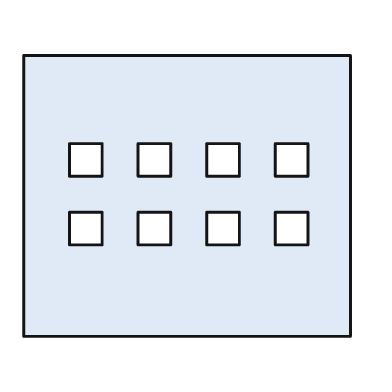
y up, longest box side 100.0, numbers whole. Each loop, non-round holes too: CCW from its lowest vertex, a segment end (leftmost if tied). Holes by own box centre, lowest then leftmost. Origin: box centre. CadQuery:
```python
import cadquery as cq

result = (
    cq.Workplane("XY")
    .moveTo(-50.0, -43.0)
    .lineTo(50.0, -43.0)
    .lineTo(50.0, 43.0)
    .lineTo(-50.0, 43.0)
    .close()
    .moveTo(-36.0, -15.0)
    .lineTo(-26.0, -15.0)
    .lineTo(-26.0, -5.0)
    .lineTo(-36.0, -5.0)
    .close()
    .moveTo(-15.0, -15.0)
    .lineTo(-5.0, -15.0)
    .lineTo(-5.0, -5.0)
    .lineTo(-15.0, -5.0)
    .close()
    .moveTo(6.0, -15.0)
    .lineTo(16.0, -15.0)
    .lineTo(16.0, -5.0)
    .lineTo(6.0, -5.0)
    .close()
    .moveTo(27.0, -15.0)
    .lineTo(37.0, -15.0)
    .lineTo(37.0, -5.0)
    .lineTo(27.0, -5.0)
    .close()
    .moveTo(-36.0, 6.0)
    .lineTo(-26.0, 6.0)
    .lineTo(-26.0, 16.0)
    .lineTo(-36.0, 16.0)
    .close()
    .moveTo(-15.0, 6.0)
    .lineTo(-5.0, 6.0)
    .lineTo(-5.0, 16.0)
    .lineTo(-15.0, 16.0)
    .close()
    .moveTo(6.0, 6.0)
    .lineTo(16.0, 6.0)
    .lineTo(16.0, 16.0)
    .lineTo(6.0, 16.0)
    .close()
    .moveTo(27.0, 6.0)
    .lineTo(37.0, 6.0)
    .lineTo(37.0, 16.0)
    .lineTo(27.0, 16.0)
    .close()
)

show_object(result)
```